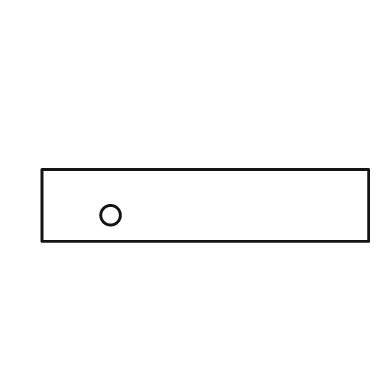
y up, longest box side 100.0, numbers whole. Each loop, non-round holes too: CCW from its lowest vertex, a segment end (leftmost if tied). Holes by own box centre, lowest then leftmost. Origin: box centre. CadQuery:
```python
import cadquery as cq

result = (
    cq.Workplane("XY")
    .moveTo(-50.0, -11.0)
    .lineTo(50.0, -11.0)
    .lineTo(50.0, 11.0)
    .lineTo(-50.0, 11.0)
    .close()
    .moveTo(-29.0, -3.0)
    .circle(3.0)
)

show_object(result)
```